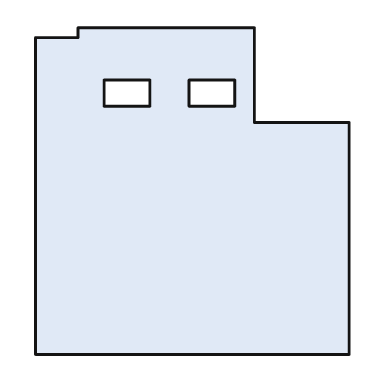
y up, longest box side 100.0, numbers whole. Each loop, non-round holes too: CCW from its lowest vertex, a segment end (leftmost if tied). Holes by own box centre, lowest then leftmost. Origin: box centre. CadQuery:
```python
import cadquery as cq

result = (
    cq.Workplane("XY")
    .moveTo(-48.0, -50.0)
    .lineTo(48.0, -50.0)
    .lineTo(48.0, 21.0)
    .lineTo(19.0, 21.0)
    .lineTo(19.0, 50.0)
    .lineTo(-35.0, 50.0)
    .lineTo(-35.0, 47.0)
    .lineTo(-48.0, 47.0)
    .close()
    .moveTo(-27.0, 26.0)
    .lineTo(-13.0, 26.0)
    .lineTo(-13.0, 34.0)
    .lineTo(-27.0, 34.0)
    .close()
    .moveTo(-1.0, 26.0)
    .lineTo(13.0, 26.0)
    .lineTo(13.0, 34.0)
    .lineTo(-1.0, 34.0)
    .close()
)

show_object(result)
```